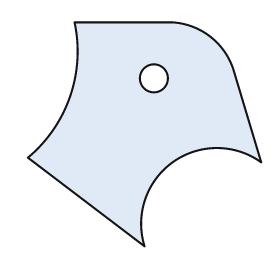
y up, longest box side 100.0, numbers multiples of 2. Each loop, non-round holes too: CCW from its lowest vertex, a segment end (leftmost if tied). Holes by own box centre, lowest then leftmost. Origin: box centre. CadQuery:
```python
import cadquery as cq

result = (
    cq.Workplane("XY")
    .moveTo(0.0, -48.0)
    .threePointArc((12.0, -12.0), (50.0, -12.0))
    .lineTo(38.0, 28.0)
    .threePointArc((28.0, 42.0), (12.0, 48.0))
    .lineTo(-30.0, 48.0)
    .threePointArc((-32.0, 16.0), (-50.0, -10.0))
    .close()
    .moveTo(4.0, 24.0)
    .circle(6.0)
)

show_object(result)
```